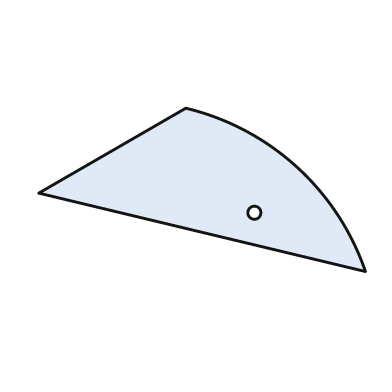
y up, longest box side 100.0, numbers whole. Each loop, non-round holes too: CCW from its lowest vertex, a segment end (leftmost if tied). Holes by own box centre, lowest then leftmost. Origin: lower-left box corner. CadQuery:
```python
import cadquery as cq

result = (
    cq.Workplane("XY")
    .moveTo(100.0, 0.0)
    .threePointArc((79.0, 32.0), (45.0, 50.0))
    .lineTo(0.0, 24.0)
    .close()
    .moveTo(66.0, 18.0)
    .circle(2.0)
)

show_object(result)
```